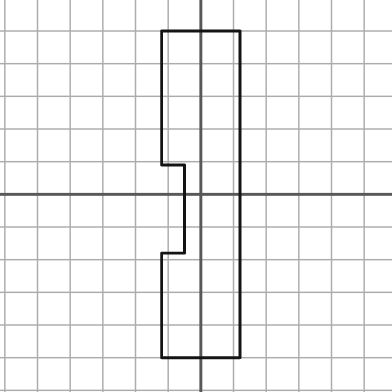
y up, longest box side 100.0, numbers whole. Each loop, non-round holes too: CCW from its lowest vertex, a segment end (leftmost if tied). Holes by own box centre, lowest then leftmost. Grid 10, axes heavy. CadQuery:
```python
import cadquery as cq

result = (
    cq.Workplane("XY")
    .moveTo(-12.0, -50.0)
    .lineTo(12.0, -50.0)
    .lineTo(12.0, 50.0)
    .lineTo(-12.0, 50.0)
    .lineTo(-12.0, 9.0)
    .lineTo(-5.0, 9.0)
    .lineTo(-5.0, -18.0)
    .lineTo(-12.0, -18.0)
    .close()
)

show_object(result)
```